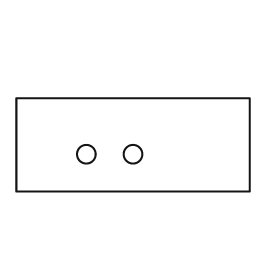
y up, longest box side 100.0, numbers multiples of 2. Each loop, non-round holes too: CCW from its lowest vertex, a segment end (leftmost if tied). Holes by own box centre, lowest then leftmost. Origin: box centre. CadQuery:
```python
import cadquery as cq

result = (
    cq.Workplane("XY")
    .moveTo(-50.0, -20.0)
    .lineTo(50.0, -20.0)
    .lineTo(50.0, 20.0)
    .lineTo(-50.0, 20.0)
    .close()
    .moveTo(-20.0, -4.0)
    .circle(4.0)
    .moveTo(0.0, -4.0)
    .circle(4.0)
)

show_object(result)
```